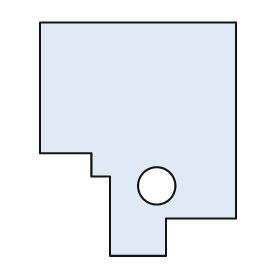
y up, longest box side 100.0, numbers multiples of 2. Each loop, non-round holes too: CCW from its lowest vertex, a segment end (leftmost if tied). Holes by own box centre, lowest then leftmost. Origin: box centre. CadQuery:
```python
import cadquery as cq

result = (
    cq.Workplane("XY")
    .moveTo(-12.0, -50.0)
    .lineTo(12.0, -50.0)
    .lineTo(12.0, -34.0)
    .lineTo(42.0, -34.0)
    .lineTo(42.0, 50.0)
    .lineTo(-42.0, 50.0)
    .lineTo(-42.0, -6.0)
    .lineTo(-20.0, -6.0)
    .lineTo(-20.0, -16.0)
    .lineTo(-12.0, -16.0)
    .close()
    .moveTo(8.0, -20.0)
    .circle(8.0)
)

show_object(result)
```